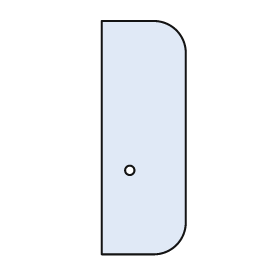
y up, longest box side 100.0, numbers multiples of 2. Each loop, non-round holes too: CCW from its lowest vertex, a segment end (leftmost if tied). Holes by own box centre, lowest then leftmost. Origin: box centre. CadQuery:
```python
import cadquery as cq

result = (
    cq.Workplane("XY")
    .moveTo(-18.0, -50.0)
    .lineTo(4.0, -50.0)
    .threePointArc((14.0, -46.0), (18.0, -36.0))
    .lineTo(18.0, 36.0)
    .threePointArc((14.0, 46.0), (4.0, 50.0))
    .lineTo(-18.0, 50.0)
    .close()
    .moveTo(-6.0, -14.0)
    .circle(2.0)
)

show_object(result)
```